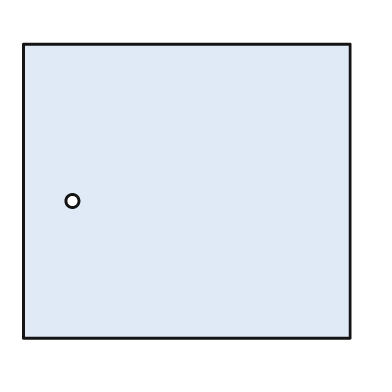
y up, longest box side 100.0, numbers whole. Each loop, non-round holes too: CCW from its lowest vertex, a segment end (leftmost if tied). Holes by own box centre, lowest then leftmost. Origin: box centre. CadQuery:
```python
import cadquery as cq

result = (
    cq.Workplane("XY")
    .moveTo(-50.0, -45.0)
    .lineTo(50.0, -45.0)
    .lineTo(50.0, 45.0)
    .lineTo(-50.0, 45.0)
    .close()
    .moveTo(-35.0, -3.0)
    .circle(2.0)
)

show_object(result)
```